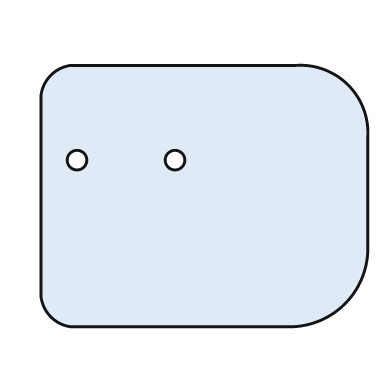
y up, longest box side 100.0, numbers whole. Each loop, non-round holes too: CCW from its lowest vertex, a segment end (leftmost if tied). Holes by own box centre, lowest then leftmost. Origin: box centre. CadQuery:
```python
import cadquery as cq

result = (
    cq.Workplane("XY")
    .moveTo(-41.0, -40.0)
    .lineTo(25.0, -40.0)
    .threePointArc((43.0, -33.0), (50.0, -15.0))
    .lineTo(50.0, 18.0)
    .threePointArc((44.0, 34.0), (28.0, 40.0))
    .lineTo(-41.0, 40.0)
    .threePointArc((-47.0, 37.0), (-50.0, 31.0))
    .lineTo(-50.0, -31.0)
    .threePointArc((-47.0, -37.0), (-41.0, -40.0))
    .close()
    .moveTo(-39.0, 11.0)
    .circle(3.0)
    .moveTo(-9.0, 11.0)
    .circle(3.0)
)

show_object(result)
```